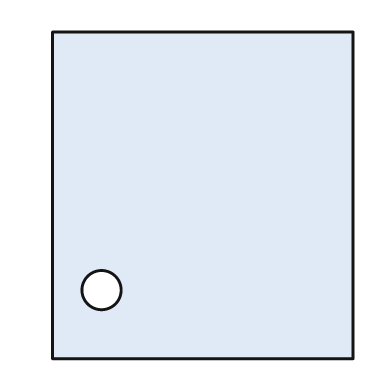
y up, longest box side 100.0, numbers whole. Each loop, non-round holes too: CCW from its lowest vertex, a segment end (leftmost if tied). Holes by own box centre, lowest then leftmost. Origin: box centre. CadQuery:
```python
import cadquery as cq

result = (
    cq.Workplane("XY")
    .moveTo(-46.0, -50.0)
    .lineTo(46.0, -50.0)
    .lineTo(46.0, 50.0)
    .lineTo(-46.0, 50.0)
    .close()
    .moveTo(-31.0, -29.0)
    .circle(6.0)
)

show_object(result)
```